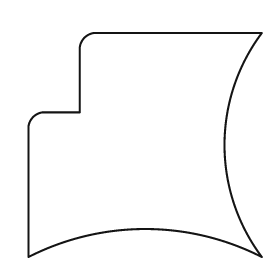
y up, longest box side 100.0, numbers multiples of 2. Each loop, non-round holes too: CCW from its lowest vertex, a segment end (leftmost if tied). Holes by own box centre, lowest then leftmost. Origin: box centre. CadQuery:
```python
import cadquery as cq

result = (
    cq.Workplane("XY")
    .moveTo(-50.0, -48.0)
    .threePointArc((0.0, -36.0), (50.0, -48.0))
    .threePointArc((34.0, 0.0), (50.0, 48.0))
    .lineTo(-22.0, 48.0)
    .threePointArc((-26.0, 46.0), (-28.0, 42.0))
    .lineTo(-28.0, 14.0)
    .lineTo(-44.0, 14.0)
    .threePointArc((-48.0, 12.0), (-50.0, 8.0))
    .close()
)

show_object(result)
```